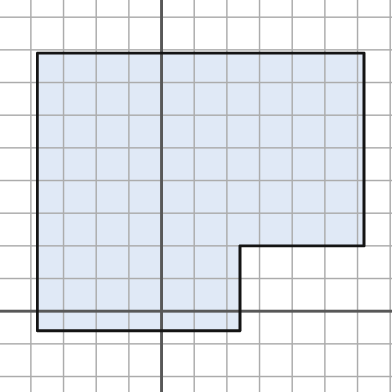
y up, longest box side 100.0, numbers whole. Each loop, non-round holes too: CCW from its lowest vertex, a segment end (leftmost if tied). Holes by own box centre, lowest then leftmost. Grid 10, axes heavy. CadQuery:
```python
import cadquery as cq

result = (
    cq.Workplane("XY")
    .moveTo(-38.0, -6.0)
    .lineTo(24.0, -6.0)
    .lineTo(24.0, 20.0)
    .lineTo(62.0, 20.0)
    .lineTo(62.0, 79.0)
    .lineTo(-38.0, 79.0)
    .close()
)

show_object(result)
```